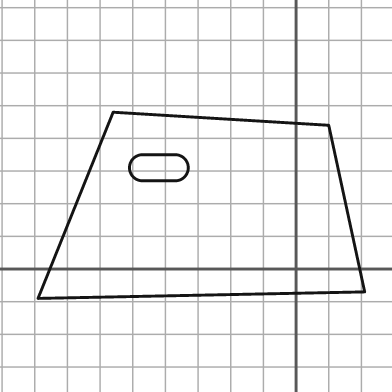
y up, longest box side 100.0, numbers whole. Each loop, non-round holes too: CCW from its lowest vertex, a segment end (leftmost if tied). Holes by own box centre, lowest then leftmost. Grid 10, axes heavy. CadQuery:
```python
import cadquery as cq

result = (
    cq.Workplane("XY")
    .moveTo(-79.0, -9.0)
    .lineTo(21.0, -7.0)
    .lineTo(10.0, 44.0)
    .lineTo(-56.0, 48.0)
    .close()
    .moveTo(-47.0, 27.0)
    .lineTo(-37.0, 27.0)
    .threePointArc((-33.0, 31.0), (-37.0, 35.0))
    .lineTo(-47.0, 35.0)
    .threePointArc((-51.0, 31.0), (-47.0, 27.0))
    .close()
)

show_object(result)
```